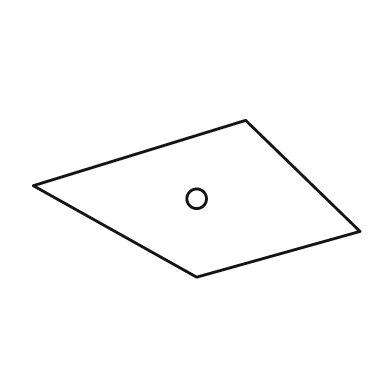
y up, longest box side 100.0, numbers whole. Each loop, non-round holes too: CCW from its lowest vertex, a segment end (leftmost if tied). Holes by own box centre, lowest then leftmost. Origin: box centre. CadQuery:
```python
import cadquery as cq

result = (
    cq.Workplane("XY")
    .moveTo(0.0, -24.0)
    .lineTo(50.0, -10.0)
    .lineTo(15.0, 24.0)
    .lineTo(-50.0, 4.0)
    .close()
    .moveTo(0.0, 0.0)
    .circle(3.0)
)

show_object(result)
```